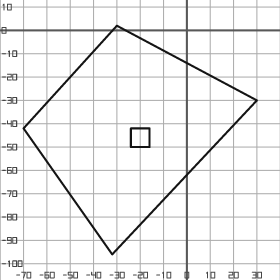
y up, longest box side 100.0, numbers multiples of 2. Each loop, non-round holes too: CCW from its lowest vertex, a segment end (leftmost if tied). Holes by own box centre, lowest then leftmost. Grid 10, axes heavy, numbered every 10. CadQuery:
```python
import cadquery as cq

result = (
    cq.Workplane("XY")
    .moveTo(-32.0, -96.0)
    .lineTo(30.0, -30.0)
    .lineTo(-30.0, 2.0)
    .lineTo(-70.0, -42.0)
    .close()
    .moveTo(-24.0, -50.0)
    .lineTo(-16.0, -50.0)
    .lineTo(-16.0, -42.0)
    .lineTo(-24.0, -42.0)
    .close()
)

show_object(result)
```